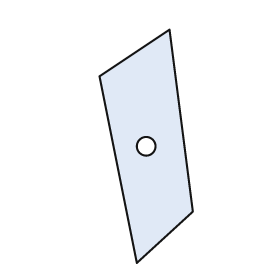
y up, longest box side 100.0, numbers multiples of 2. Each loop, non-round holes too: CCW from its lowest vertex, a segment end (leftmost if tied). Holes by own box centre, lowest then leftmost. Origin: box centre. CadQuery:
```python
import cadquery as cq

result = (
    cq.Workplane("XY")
    .moveTo(-4.0, -50.0)
    .lineTo(20.0, -28.0)
    .lineTo(10.0, 50.0)
    .lineTo(-20.0, 30.0)
    .close()
    .moveTo(0.0, 0.0)
    .circle(4.0)
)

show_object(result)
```